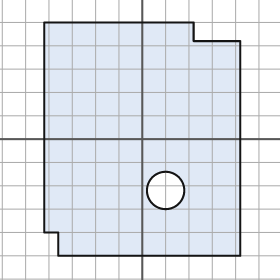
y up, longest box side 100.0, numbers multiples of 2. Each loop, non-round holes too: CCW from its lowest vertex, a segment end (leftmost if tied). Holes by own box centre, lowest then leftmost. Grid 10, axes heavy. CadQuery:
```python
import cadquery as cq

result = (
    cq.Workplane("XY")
    .moveTo(-36.0, -50.0)
    .lineTo(42.0, -50.0)
    .lineTo(42.0, 42.0)
    .lineTo(22.0, 42.0)
    .lineTo(22.0, 50.0)
    .lineTo(-42.0, 50.0)
    .lineTo(-42.0, -40.0)
    .lineTo(-36.0, -40.0)
    .close()
    .moveTo(10.0, -22.0)
    .circle(8.0)
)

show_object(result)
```